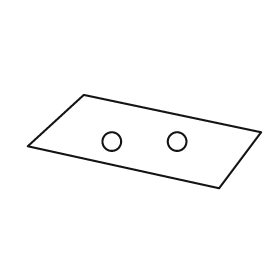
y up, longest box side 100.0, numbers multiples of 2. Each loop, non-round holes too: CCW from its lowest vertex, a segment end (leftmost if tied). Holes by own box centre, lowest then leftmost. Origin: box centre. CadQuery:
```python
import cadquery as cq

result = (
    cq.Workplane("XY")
    .moveTo(32.0, -20.0)
    .lineTo(50.0, 4.0)
    .lineTo(-26.0, 20.0)
    .lineTo(-50.0, -2.0)
    .close()
    .moveTo(-14.0, 0.0)
    .circle(4.0)
    .moveTo(14.0, 0.0)
    .circle(4.0)
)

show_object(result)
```